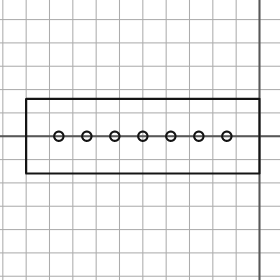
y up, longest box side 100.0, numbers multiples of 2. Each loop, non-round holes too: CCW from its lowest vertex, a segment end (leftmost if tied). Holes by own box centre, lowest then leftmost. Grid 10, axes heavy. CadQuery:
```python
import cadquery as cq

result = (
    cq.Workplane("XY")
    .moveTo(-100.0, -16.0)
    .lineTo(0.0, -16.0)
    .lineTo(0.0, 16.0)
    .lineTo(-100.0, 16.0)
    .close()
    .moveTo(-86.0, 0.0)
    .circle(2.0)
    .moveTo(-74.0, 0.0)
    .circle(2.0)
    .moveTo(-62.0, 0.0)
    .circle(2.0)
    .moveTo(-50.0, 0.0)
    .circle(2.0)
    .moveTo(-38.0, 0.0)
    .circle(2.0)
    .moveTo(-26.0, 0.0)
    .circle(2.0)
    .moveTo(-14.0, 0.0)
    .circle(2.0)
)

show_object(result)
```